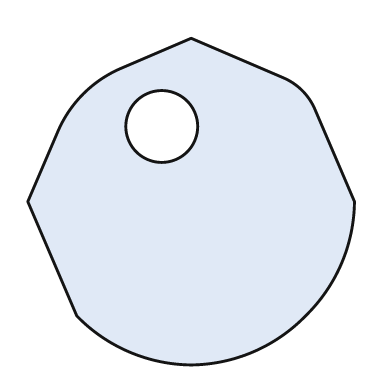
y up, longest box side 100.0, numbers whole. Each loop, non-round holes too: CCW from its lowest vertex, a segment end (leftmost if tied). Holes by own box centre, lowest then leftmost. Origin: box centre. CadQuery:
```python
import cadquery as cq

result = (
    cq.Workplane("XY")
    .moveTo(0.0, -50.0)
    .threePointArc((19.0, -46.0), (35.0, -35.0))
    .threePointArc((46.0, -19.0), (50.0, 0.0))
    .lineTo(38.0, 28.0)
    .threePointArc((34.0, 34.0), (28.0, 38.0))
    .lineTo(0.0, 50.0)
    .lineTo(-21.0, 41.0)
    .threePointArc((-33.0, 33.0), (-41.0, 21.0))
    .lineTo(-50.0, 0.0)
    .lineTo(-35.0, -35.0)
    .threePointArc((-19.0, -46.0), (0.0, -50.0))
    .close()
    .moveTo(-9.0, 23.0)
    .circle(11.0)
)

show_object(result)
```